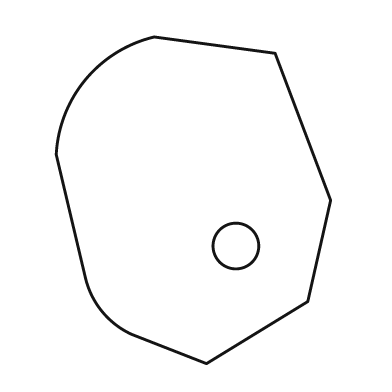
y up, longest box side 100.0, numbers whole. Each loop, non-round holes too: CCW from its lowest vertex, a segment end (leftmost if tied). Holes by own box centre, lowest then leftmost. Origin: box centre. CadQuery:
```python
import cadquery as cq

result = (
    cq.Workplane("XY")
    .moveTo(4.0, -50.0)
    .lineTo(35.0, -31.0)
    .lineTo(42.0, 0.0)
    .lineTo(25.0, 45.0)
    .lineTo(-12.0, 50.0)
    .threePointArc((-33.0, 37.0), (-42.0, 14.0))
    .lineTo(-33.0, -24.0)
    .threePointArc((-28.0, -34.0), (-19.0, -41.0))
    .close()
    .moveTo(13.0, -14.0)
    .circle(7.0)
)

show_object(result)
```